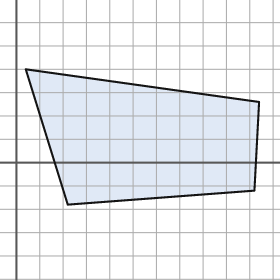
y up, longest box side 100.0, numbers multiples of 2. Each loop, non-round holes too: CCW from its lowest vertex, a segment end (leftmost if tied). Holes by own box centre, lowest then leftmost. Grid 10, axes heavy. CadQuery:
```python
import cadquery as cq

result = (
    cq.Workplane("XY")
    .moveTo(22.0, -18.0)
    .lineTo(102.0, -12.0)
    .lineTo(104.0, 26.0)
    .lineTo(4.0, 40.0)
    .close()
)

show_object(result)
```